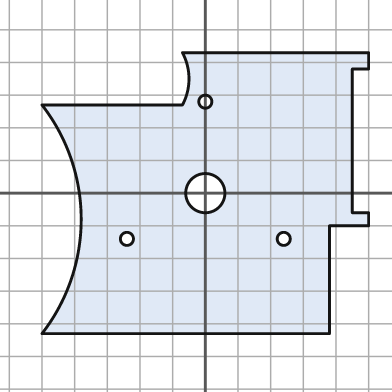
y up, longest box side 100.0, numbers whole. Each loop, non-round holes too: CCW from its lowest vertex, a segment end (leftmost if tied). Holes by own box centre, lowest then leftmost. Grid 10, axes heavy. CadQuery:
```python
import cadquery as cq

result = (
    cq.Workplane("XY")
    .moveTo(-50.0, -43.0)
    .lineTo(38.0, -43.0)
    .lineTo(38.0, -10.0)
    .lineTo(50.0, -10.0)
    .lineTo(50.0, -6.0)
    .lineTo(45.0, -6.0)
    .lineTo(45.0, 38.0)
    .lineTo(50.0, 38.0)
    .lineTo(50.0, 43.0)
    .lineTo(-7.0, 43.0)
    .threePointArc((-5.0, 35.0), (-7.0, 27.0))
    .lineTo(-50.0, 27.0)
    .threePointArc((-38.0, -8.0), (-50.0, -43.0))
    .close()
    .moveTo(-24.0, -14.0)
    .circle(2.0)
    .moveTo(24.0, -14.0)
    .circle(2.0)
    .moveTo(0.0, 0.0)
    .circle(6.0)
    .moveTo(0.0, 28.0)
    .circle(2.0)
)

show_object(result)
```